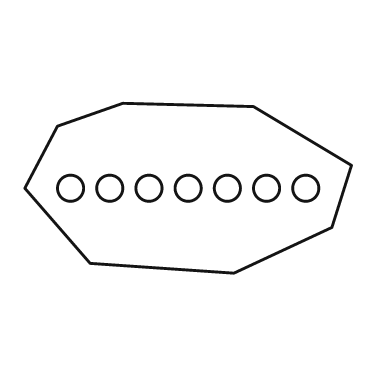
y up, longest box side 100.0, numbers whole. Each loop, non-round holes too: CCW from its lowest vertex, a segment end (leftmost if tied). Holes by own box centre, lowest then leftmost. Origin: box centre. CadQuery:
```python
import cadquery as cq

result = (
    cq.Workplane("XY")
    .moveTo(14.0, -26.0)
    .lineTo(44.0, -12.0)
    .lineTo(50.0, 7.0)
    .lineTo(20.0, 25.0)
    .lineTo(-20.0, 26.0)
    .lineTo(-40.0, 19.0)
    .lineTo(-50.0, 0.0)
    .lineTo(-30.0, -23.0)
    .close()
    .moveTo(-36.0, 0.0)
    .circle(4.0)
    .moveTo(-24.0, 0.0)
    .circle(4.0)
    .moveTo(-12.0, 0.0)
    .circle(4.0)
    .moveTo(0.0, 0.0)
    .circle(4.0)
    .moveTo(12.0, 0.0)
    .circle(4.0)
    .moveTo(24.0, 0.0)
    .circle(4.0)
    .moveTo(36.0, 0.0)
    .circle(4.0)
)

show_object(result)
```